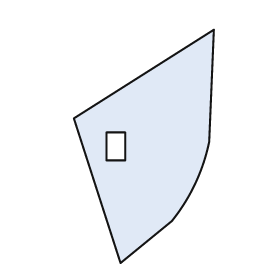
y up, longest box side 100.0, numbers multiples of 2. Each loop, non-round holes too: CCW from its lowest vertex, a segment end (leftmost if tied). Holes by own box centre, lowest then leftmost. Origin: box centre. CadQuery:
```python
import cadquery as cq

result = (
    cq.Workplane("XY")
    .moveTo(-10.0, -50.0)
    .lineTo(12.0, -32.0)
    .threePointArc((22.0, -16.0), (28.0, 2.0))
    .lineTo(30.0, 50.0)
    .lineTo(-30.0, 12.0)
    .close()
    .moveTo(-16.0, -6.0)
    .lineTo(-8.0, -6.0)
    .lineTo(-8.0, 6.0)
    .lineTo(-16.0, 6.0)
    .close()
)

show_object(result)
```